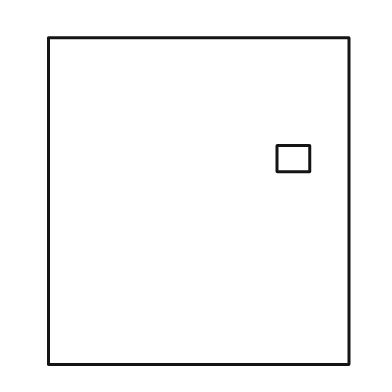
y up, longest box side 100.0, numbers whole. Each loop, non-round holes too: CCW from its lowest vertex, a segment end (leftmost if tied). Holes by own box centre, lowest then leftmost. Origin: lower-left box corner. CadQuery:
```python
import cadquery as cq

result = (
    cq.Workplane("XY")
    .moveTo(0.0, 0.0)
    .lineTo(92.0, 0.0)
    .lineTo(92.0, 100.0)
    .lineTo(0.0, 100.0)
    .close()
    .moveTo(70.0, 59.0)
    .lineTo(80.0, 59.0)
    .lineTo(80.0, 67.0)
    .lineTo(70.0, 67.0)
    .close()
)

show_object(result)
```